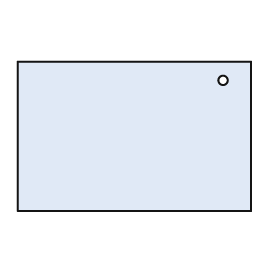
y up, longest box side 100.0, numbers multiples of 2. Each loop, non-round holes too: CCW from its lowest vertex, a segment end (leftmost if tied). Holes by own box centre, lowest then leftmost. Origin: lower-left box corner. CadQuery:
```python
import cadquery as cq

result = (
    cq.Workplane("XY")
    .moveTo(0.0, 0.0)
    .lineTo(100.0, 0.0)
    .lineTo(100.0, 64.0)
    .lineTo(0.0, 64.0)
    .close()
    .moveTo(88.0, 56.0)
    .circle(2.0)
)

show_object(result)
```